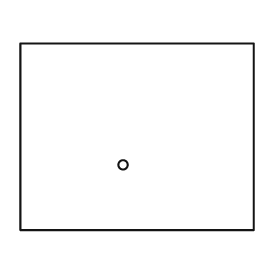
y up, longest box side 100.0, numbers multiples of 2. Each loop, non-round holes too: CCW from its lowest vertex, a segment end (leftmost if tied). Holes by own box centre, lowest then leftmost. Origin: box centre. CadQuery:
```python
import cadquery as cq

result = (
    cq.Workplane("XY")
    .moveTo(-50.0, -40.0)
    .lineTo(50.0, -40.0)
    .lineTo(50.0, 40.0)
    .lineTo(-50.0, 40.0)
    .close()
    .moveTo(-6.0, -12.0)
    .circle(2.0)
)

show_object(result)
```